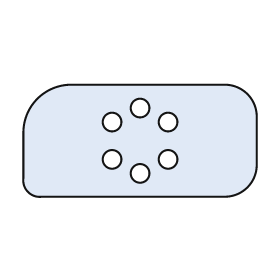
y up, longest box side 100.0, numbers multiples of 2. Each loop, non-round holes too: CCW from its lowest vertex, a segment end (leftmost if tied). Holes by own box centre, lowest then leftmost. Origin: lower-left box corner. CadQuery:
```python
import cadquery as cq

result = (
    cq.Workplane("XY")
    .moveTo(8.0, 0.0)
    .lineTo(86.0, 0.0)
    .threePointArc((96.0, 4.0), (100.0, 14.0))
    .lineTo(100.0, 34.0)
    .threePointArc((96.0, 44.0), (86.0, 48.0))
    .lineTo(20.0, 48.0)
    .threePointArc((6.0, 42.0), (0.0, 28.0))
    .lineTo(0.0, 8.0)
    .threePointArc((2.0, 2.0), (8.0, 0.0))
    .close()
    .moveTo(50.0, 10.0)
    .circle(4.0)
    .moveTo(38.0, 16.0)
    .circle(4.0)
    .moveTo(62.0, 16.0)
    .circle(4.0)
    .moveTo(38.0, 32.0)
    .circle(4.0)
    .moveTo(62.0, 32.0)
    .circle(4.0)
    .moveTo(50.0, 38.0)
    .circle(4.0)
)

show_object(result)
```